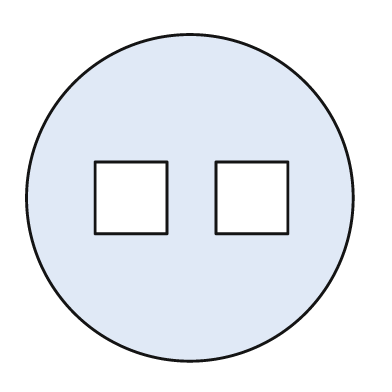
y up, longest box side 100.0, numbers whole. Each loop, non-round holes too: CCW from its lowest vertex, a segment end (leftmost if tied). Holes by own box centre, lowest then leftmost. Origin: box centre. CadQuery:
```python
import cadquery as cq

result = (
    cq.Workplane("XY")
    .moveTo(0.0, 0.0)
    .circle(50.0)
    .moveTo(-29.0, -11.0)
    .lineTo(-7.0, -11.0)
    .lineTo(-7.0, 11.0)
    .lineTo(-29.0, 11.0)
    .close()
    .moveTo(8.0, -11.0)
    .lineTo(30.0, -11.0)
    .lineTo(30.0, 11.0)
    .lineTo(8.0, 11.0)
    .close()
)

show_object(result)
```